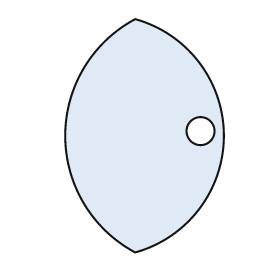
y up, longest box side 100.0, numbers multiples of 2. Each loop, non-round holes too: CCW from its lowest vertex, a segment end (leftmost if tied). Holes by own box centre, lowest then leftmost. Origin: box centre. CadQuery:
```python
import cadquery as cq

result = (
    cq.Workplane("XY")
    .moveTo(-4.0, -50.0)
    .threePointArc((34.0, 0.0), (-4.0, 50.0))
    .threePointArc((-34.0, 0.0), (-4.0, -50.0))
    .close()
    .moveTo(24.0, 2.0)
    .circle(6.0)
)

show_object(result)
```